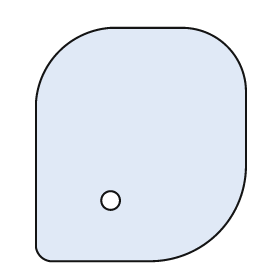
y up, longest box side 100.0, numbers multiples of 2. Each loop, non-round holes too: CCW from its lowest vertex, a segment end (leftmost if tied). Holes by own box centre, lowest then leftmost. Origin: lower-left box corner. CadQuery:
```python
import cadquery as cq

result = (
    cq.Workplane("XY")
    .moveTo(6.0, 0.0)
    .lineTo(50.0, 0.0)
    .threePointArc((78.0, 12.0), (90.0, 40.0))
    .lineTo(90.0, 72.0)
    .threePointArc((82.0, 92.0), (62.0, 100.0))
    .lineTo(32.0, 100.0)
    .threePointArc((10.0, 90.0), (0.0, 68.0))
    .lineTo(0.0, 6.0)
    .threePointArc((2.0, 2.0), (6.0, 0.0))
    .close()
    .moveTo(32.0, 26.0)
    .circle(4.0)
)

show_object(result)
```